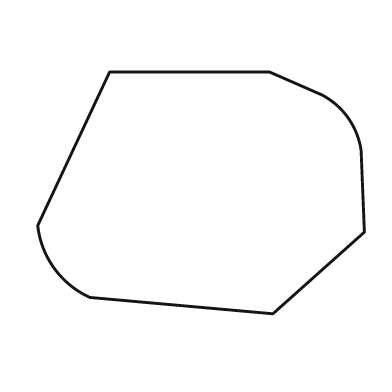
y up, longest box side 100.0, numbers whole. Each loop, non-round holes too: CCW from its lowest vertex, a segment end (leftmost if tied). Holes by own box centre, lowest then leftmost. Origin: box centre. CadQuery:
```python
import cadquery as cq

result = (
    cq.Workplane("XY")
    .moveTo(22.0, -37.0)
    .lineTo(50.0, -12.0)
    .lineTo(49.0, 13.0)
    .threePointArc((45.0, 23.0), (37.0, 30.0))
    .lineTo(21.0, 37.0)
    .lineTo(-28.0, 37.0)
    .lineTo(-50.0, -10.0)
    .threePointArc((-45.0, -23.0), (-34.0, -32.0))
    .close()
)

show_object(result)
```